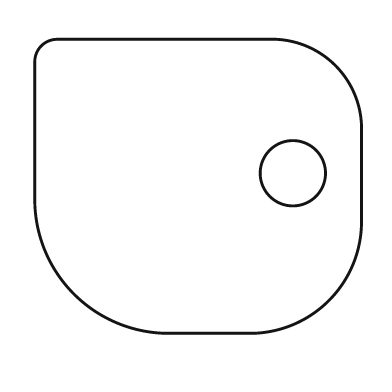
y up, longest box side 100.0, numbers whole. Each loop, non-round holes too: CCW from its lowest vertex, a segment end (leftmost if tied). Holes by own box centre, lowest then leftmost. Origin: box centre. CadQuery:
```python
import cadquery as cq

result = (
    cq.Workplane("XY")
    .moveTo(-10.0, -45.0)
    .lineTo(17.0, -45.0)
    .threePointArc((40.0, -35.0), (50.0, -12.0))
    .lineTo(50.0, 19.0)
    .threePointArc((42.0, 37.0), (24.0, 45.0))
    .lineTo(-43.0, 45.0)
    .threePointArc((-48.0, 43.0), (-50.0, 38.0))
    .lineTo(-50.0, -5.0)
    .threePointArc((-38.0, -33.0), (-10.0, -45.0))
    .close()
    .moveTo(29.0, 4.0)
    .circle(10.0)
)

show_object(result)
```